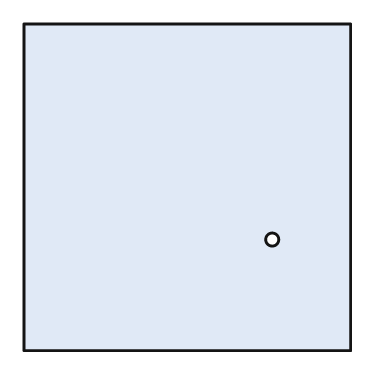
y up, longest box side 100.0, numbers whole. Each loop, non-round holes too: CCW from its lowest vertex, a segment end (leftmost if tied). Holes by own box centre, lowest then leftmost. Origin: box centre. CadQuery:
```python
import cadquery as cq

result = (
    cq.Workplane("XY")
    .moveTo(-50.0, -50.0)
    .lineTo(50.0, -50.0)
    .lineTo(50.0, 50.0)
    .lineTo(-50.0, 50.0)
    .close()
    .moveTo(26.0, -16.0)
    .circle(2.0)
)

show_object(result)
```